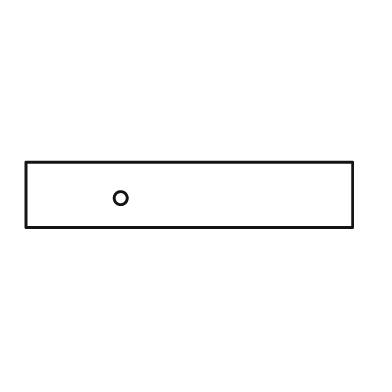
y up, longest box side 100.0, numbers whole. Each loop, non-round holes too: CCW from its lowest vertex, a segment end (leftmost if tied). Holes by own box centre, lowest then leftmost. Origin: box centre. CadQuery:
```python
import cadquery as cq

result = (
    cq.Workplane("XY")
    .moveTo(-50.0, -10.0)
    .lineTo(50.0, -10.0)
    .lineTo(50.0, 10.0)
    .lineTo(-50.0, 10.0)
    .close()
    .moveTo(-21.0, -1.0)
    .circle(2.0)
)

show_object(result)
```